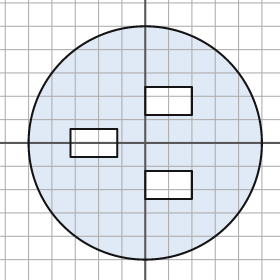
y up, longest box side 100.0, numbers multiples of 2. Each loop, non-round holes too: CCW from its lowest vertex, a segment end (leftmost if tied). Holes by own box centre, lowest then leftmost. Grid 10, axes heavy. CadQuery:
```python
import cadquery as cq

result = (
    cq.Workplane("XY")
    .moveTo(0.0, 0.0)
    .circle(50.0)
    .moveTo(0.0, -24.0)
    .lineTo(20.0, -24.0)
    .lineTo(20.0, -12.0)
    .lineTo(0.0, -12.0)
    .close()
    .moveTo(-32.0, -6.0)
    .lineTo(-12.0, -6.0)
    .lineTo(-12.0, 6.0)
    .lineTo(-32.0, 6.0)
    .close()
    .moveTo(0.0, 12.0)
    .lineTo(20.0, 12.0)
    .lineTo(20.0, 24.0)
    .lineTo(0.0, 24.0)
    .close()
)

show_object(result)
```